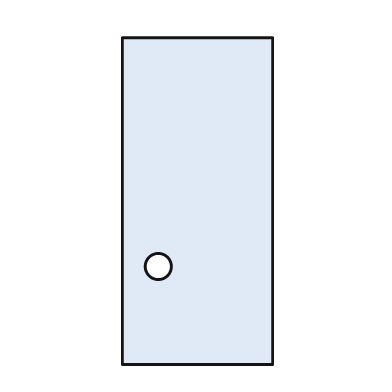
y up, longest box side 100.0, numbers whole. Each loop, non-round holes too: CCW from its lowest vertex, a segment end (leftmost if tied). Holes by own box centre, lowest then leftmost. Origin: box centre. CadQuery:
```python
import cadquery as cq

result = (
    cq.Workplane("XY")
    .moveTo(-23.0, -50.0)
    .lineTo(23.0, -50.0)
    .lineTo(23.0, 50.0)
    .lineTo(-23.0, 50.0)
    .close()
    .moveTo(-12.0, -20.0)
    .circle(4.0)
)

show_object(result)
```